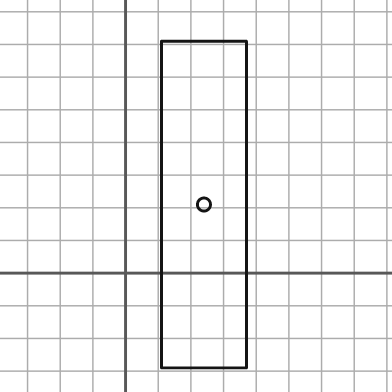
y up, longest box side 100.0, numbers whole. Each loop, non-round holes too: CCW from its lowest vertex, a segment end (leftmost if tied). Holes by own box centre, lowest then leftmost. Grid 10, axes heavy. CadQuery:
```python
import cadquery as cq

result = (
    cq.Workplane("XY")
    .moveTo(11.0, -29.0)
    .lineTo(37.0, -29.0)
    .lineTo(37.0, 71.0)
    .lineTo(11.0, 71.0)
    .close()
    .moveTo(24.0, 21.0)
    .circle(2.0)
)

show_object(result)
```